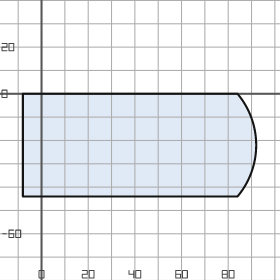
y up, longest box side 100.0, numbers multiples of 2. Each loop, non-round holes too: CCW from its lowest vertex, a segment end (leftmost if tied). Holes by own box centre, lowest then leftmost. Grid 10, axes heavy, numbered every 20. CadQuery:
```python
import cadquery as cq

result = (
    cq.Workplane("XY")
    .moveTo(-8.0, -44.0)
    .lineTo(84.0, -44.0)
    .threePointArc((92.0, -22.0), (84.0, 0.0))
    .lineTo(-8.0, 0.0)
    .close()
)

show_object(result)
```